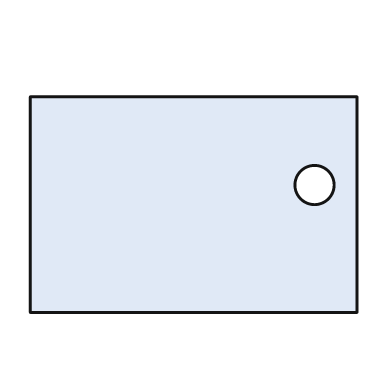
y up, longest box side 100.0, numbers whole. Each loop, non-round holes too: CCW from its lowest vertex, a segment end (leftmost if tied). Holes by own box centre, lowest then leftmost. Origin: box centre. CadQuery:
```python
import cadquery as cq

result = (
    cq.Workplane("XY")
    .moveTo(-50.0, -33.0)
    .lineTo(50.0, -33.0)
    .lineTo(50.0, 33.0)
    .lineTo(-50.0, 33.0)
    .close()
    .moveTo(37.0, 6.0)
    .circle(6.0)
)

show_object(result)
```